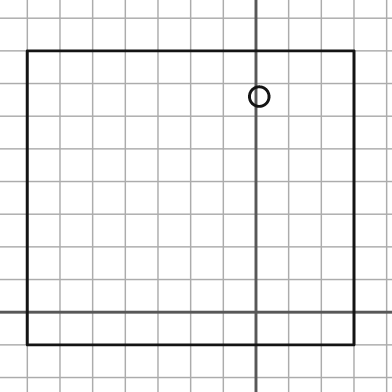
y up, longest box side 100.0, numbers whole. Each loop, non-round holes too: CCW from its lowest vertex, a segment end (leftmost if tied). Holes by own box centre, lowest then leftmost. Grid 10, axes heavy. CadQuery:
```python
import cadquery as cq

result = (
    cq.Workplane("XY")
    .moveTo(-70.0, -10.0)
    .lineTo(30.0, -10.0)
    .lineTo(30.0, 80.0)
    .lineTo(-70.0, 80.0)
    .close()
    .moveTo(1.0, 66.0)
    .circle(3.0)
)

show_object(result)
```